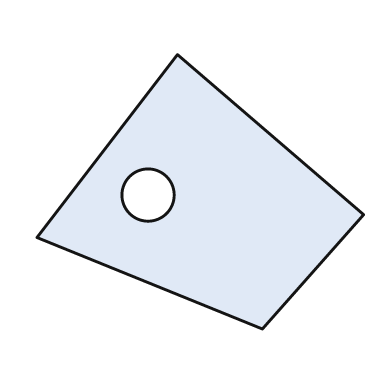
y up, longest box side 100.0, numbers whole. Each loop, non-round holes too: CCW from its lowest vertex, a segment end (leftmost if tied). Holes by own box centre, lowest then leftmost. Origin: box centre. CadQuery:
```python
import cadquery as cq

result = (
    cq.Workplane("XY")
    .moveTo(19.0, -42.0)
    .lineTo(50.0, -7.0)
    .lineTo(-7.0, 42.0)
    .lineTo(-50.0, -14.0)
    .close()
    .moveTo(-16.0, -1.0)
    .circle(8.0)
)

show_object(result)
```